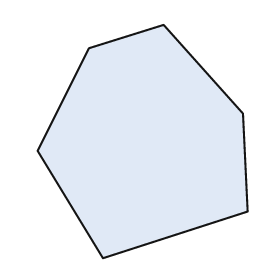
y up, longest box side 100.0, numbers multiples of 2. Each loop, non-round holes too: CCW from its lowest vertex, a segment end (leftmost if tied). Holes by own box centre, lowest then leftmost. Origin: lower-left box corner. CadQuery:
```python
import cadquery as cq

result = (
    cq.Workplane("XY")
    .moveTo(28.0, 0.0)
    .lineTo(90.0, 20.0)
    .lineTo(88.0, 62.0)
    .lineTo(54.0, 100.0)
    .lineTo(22.0, 90.0)
    .lineTo(0.0, 46.0)
    .close()
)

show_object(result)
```